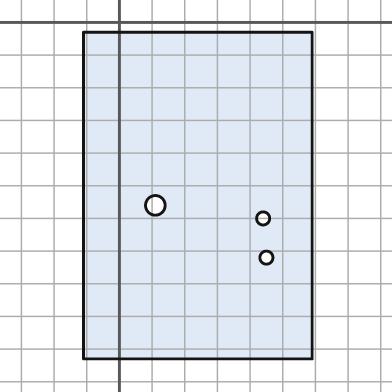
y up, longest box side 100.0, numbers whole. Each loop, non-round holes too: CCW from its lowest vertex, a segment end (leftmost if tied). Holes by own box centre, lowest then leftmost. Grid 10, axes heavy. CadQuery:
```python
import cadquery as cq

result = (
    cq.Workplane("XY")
    .moveTo(-11.0, -103.0)
    .lineTo(59.0, -103.0)
    .lineTo(59.0, -3.0)
    .lineTo(-11.0, -3.0)
    .close()
    .moveTo(45.0, -72.0)
    .circle(2.0)
    .moveTo(44.0, -60.0)
    .circle(2.0)
    .moveTo(11.0, -56.0)
    .circle(3.0)
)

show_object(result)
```